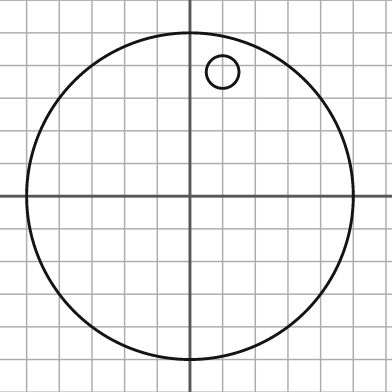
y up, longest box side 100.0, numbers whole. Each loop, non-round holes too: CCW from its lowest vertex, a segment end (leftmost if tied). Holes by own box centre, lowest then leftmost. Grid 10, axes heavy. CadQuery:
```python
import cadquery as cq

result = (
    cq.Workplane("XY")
    .moveTo(0.0, 0.0)
    .circle(50.0)
    .moveTo(10.0, 38.0)
    .circle(5.0)
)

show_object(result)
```